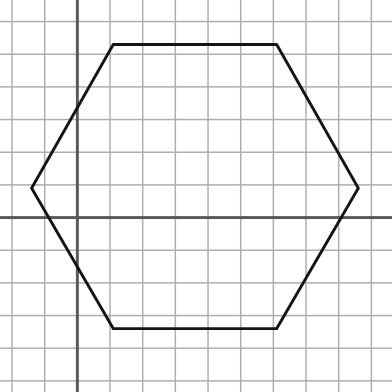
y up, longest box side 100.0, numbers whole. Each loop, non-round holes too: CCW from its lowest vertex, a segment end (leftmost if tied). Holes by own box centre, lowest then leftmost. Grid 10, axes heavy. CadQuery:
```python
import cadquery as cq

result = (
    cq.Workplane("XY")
    .moveTo(11.0, -34.0)
    .lineTo(61.0, -34.0)
    .lineTo(86.0, 9.0)
    .lineTo(61.0, 53.0)
    .lineTo(11.0, 53.0)
    .lineTo(-14.0, 9.0)
    .close()
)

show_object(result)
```